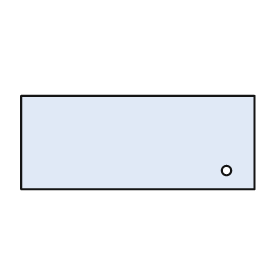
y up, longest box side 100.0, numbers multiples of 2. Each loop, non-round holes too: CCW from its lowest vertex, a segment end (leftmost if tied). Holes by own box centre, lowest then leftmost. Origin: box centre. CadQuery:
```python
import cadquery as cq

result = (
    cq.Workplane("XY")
    .moveTo(-50.0, -20.0)
    .lineTo(50.0, -20.0)
    .lineTo(50.0, 20.0)
    .lineTo(-50.0, 20.0)
    .close()
    .moveTo(38.0, -12.0)
    .circle(2.0)
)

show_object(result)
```